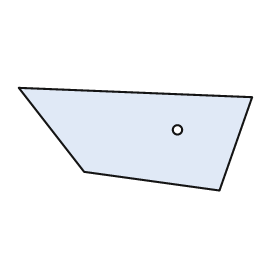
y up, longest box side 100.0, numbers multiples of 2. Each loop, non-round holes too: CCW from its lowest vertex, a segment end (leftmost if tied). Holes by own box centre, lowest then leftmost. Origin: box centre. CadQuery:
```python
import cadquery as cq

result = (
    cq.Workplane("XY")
    .moveTo(36.0, -22.0)
    .lineTo(50.0, 18.0)
    .lineTo(-50.0, 22.0)
    .lineTo(-22.0, -14.0)
    .close()
    .moveTo(18.0, 4.0)
    .circle(2.0)
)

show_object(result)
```